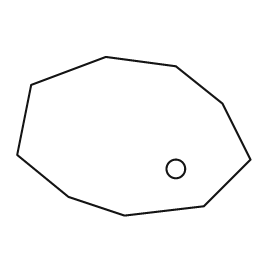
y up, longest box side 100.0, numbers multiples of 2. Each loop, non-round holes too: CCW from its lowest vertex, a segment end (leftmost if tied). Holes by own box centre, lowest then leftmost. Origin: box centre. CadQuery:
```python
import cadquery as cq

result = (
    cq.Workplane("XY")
    .moveTo(-4.0, -34.0)
    .lineTo(30.0, -30.0)
    .lineTo(50.0, -10.0)
    .lineTo(38.0, 14.0)
    .lineTo(18.0, 30.0)
    .lineTo(-12.0, 34.0)
    .lineTo(-44.0, 22.0)
    .lineTo(-50.0, -8.0)
    .lineTo(-28.0, -26.0)
    .close()
    .moveTo(18.0, -14.0)
    .circle(4.0)
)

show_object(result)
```